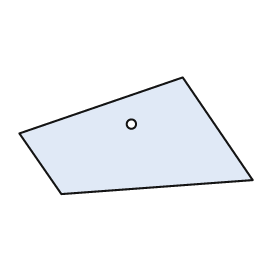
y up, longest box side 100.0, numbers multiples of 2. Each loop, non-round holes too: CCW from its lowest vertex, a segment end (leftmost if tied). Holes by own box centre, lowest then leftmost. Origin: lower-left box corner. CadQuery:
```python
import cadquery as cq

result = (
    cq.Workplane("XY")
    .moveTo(18.0, 0.0)
    .lineTo(100.0, 6.0)
    .lineTo(70.0, 50.0)
    .lineTo(0.0, 26.0)
    .close()
    .moveTo(48.0, 30.0)
    .circle(2.0)
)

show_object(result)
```